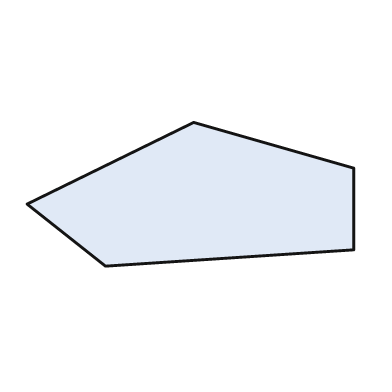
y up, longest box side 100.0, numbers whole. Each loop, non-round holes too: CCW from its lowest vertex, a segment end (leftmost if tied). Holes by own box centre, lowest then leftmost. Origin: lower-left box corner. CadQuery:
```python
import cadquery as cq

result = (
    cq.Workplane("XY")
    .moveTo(24.0, 0.0)
    .lineTo(100.0, 5.0)
    .lineTo(100.0, 30.0)
    .lineTo(51.0, 44.0)
    .lineTo(0.0, 19.0)
    .close()
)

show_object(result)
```